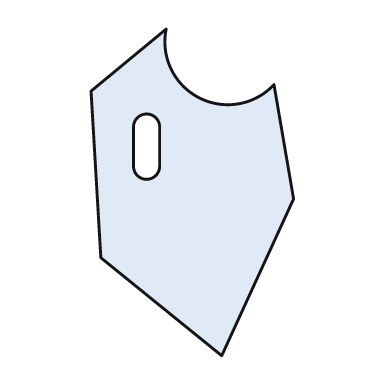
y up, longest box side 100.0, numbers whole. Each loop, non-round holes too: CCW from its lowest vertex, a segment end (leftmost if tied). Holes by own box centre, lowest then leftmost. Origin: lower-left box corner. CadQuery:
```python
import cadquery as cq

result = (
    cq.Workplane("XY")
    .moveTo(40.0, 0.0)
    .lineTo(62.0, 48.0)
    .lineTo(56.0, 83.0)
    .threePointArc((33.0, 79.0), (23.0, 100.0))
    .lineTo(0.0, 81.0)
    .lineTo(3.0, 30.0)
    .close()
    .moveTo(13.0, 58.0)
    .threePointArc((17.0, 54.0), (21.0, 58.0))
    .lineTo(21.0, 70.0)
    .threePointArc((17.0, 74.0), (13.0, 70.0))
    .close()
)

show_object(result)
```